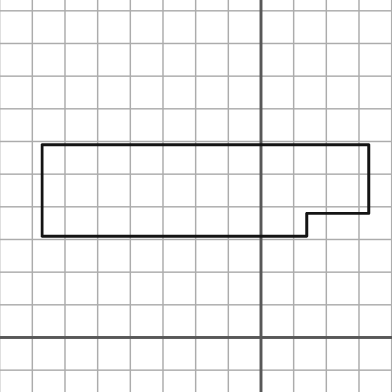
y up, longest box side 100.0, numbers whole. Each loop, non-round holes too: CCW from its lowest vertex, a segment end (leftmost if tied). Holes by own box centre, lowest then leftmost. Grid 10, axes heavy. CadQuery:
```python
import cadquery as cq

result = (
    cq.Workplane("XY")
    .moveTo(-67.0, 31.0)
    .lineTo(14.0, 31.0)
    .lineTo(14.0, 38.0)
    .lineTo(33.0, 38.0)
    .lineTo(33.0, 59.0)
    .lineTo(-67.0, 59.0)
    .close()
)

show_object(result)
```